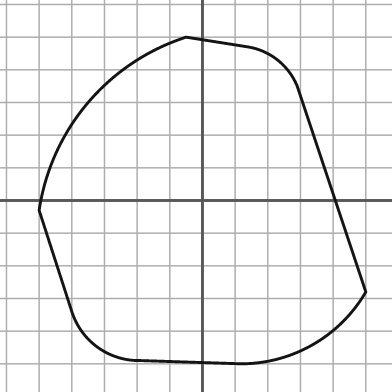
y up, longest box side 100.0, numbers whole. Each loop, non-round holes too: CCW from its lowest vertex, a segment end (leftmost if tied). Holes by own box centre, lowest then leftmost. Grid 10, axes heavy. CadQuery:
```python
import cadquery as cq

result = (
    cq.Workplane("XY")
    .moveTo(12.0, -50.0)
    .threePointArc((34.0, -44.0), (50.0, -28.0))
    .lineTo(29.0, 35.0)
    .threePointArc((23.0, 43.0), (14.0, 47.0))
    .lineTo(-5.0, 50.0)
    .threePointArc((-35.0, 30.0), (-50.0, -3.0))
    .lineTo(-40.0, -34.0)
    .threePointArc((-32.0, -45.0), (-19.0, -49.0))
    .close()
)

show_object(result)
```